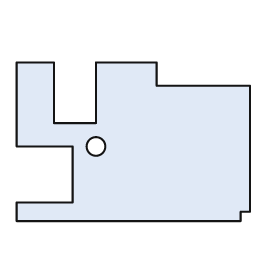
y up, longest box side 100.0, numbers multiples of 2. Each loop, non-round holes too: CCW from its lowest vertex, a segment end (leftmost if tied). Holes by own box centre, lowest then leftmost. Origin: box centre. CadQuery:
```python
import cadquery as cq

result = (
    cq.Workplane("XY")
    .moveTo(-50.0, -34.0)
    .lineTo(46.0, -34.0)
    .lineTo(46.0, -30.0)
    .lineTo(50.0, -30.0)
    .lineTo(50.0, 24.0)
    .lineTo(10.0, 24.0)
    .lineTo(10.0, 34.0)
    .lineTo(-16.0, 34.0)
    .lineTo(-16.0, 8.0)
    .lineTo(-34.0, 8.0)
    .lineTo(-34.0, 34.0)
    .lineTo(-50.0, 34.0)
    .lineTo(-50.0, -2.0)
    .lineTo(-26.0, -2.0)
    .lineTo(-26.0, -26.0)
    .lineTo(-50.0, -26.0)
    .close()
    .moveTo(-16.0, -2.0)
    .circle(4.0)
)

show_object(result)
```